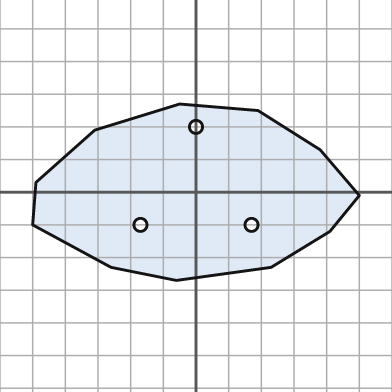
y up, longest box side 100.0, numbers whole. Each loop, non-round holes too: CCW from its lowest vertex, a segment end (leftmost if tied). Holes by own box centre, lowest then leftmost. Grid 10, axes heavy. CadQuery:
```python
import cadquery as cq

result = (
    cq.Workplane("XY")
    .moveTo(-6.0, -27.0)
    .lineTo(23.0, -23.0)
    .lineTo(41.0, -12.0)
    .lineTo(50.0, -1.0)
    .lineTo(38.0, 13.0)
    .lineTo(19.0, 25.0)
    .lineTo(-5.0, 27.0)
    .lineTo(-31.0, 19.0)
    .lineTo(-49.0, 3.0)
    .lineTo(-50.0, -10.0)
    .lineTo(-26.0, -23.0)
    .close()
    .moveTo(-17.0, -10.0)
    .circle(2.0)
    .moveTo(17.0, -10.0)
    .circle(2.0)
    .moveTo(0.0, 20.0)
    .circle(2.0)
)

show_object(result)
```